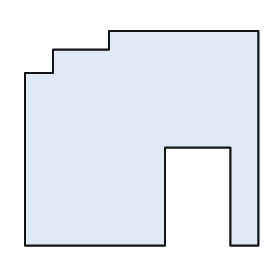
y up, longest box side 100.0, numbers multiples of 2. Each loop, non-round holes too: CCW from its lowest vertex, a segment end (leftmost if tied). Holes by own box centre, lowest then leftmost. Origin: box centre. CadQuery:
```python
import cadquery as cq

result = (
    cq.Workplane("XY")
    .moveTo(-50.0, -46.0)
    .lineTo(10.0, -46.0)
    .lineTo(10.0, -4.0)
    .lineTo(38.0, -4.0)
    .lineTo(38.0, -46.0)
    .lineTo(50.0, -46.0)
    .lineTo(50.0, 46.0)
    .lineTo(-14.0, 46.0)
    .lineTo(-14.0, 38.0)
    .lineTo(-38.0, 38.0)
    .lineTo(-38.0, 28.0)
    .lineTo(-50.0, 28.0)
    .close()
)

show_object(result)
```